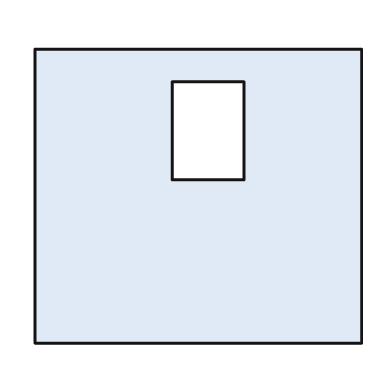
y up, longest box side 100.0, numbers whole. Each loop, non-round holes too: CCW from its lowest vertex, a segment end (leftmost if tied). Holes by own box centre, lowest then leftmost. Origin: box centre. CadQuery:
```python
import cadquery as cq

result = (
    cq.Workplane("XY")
    .moveTo(-50.0, -45.0)
    .lineTo(50.0, -45.0)
    .lineTo(50.0, 45.0)
    .lineTo(-50.0, 45.0)
    .close()
    .moveTo(-8.0, 5.0)
    .lineTo(14.0, 5.0)
    .lineTo(14.0, 35.0)
    .lineTo(-8.0, 35.0)
    .close()
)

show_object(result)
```